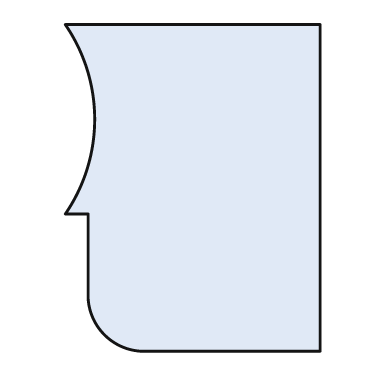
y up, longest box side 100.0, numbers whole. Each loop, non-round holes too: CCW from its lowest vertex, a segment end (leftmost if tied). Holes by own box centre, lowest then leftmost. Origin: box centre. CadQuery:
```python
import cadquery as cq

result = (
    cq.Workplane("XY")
    .moveTo(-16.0, -50.0)
    .lineTo(39.0, -50.0)
    .lineTo(39.0, 50.0)
    .lineTo(-39.0, 50.0)
    .threePointArc((-30.0, 21.0), (-39.0, -8.0))
    .lineTo(-32.0, -8.0)
    .lineTo(-32.0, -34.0)
    .threePointArc((-27.0, -45.0), (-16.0, -50.0))
    .close()
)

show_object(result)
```